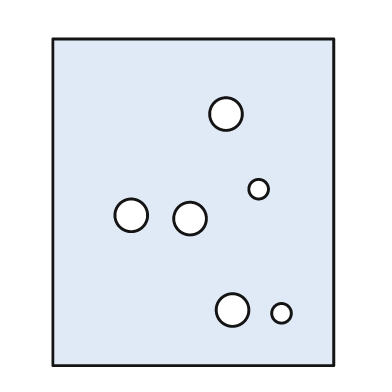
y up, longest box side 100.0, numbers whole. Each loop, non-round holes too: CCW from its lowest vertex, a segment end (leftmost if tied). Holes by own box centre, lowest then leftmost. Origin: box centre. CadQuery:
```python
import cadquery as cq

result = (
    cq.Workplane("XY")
    .moveTo(-43.0, -50.0)
    .lineTo(43.0, -50.0)
    .lineTo(43.0, 50.0)
    .lineTo(-43.0, 50.0)
    .close()
    .moveTo(27.0, -34.0)
    .circle(3.0)
    .moveTo(12.0, -33.0)
    .circle(5.0)
    .moveTo(-1.0, -5.0)
    .circle(5.0)
    .moveTo(-19.0, -4.0)
    .circle(5.0)
    .moveTo(20.0, 4.0)
    .circle(3.0)
    .moveTo(10.0, 27.0)
    .circle(5.0)
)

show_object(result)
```